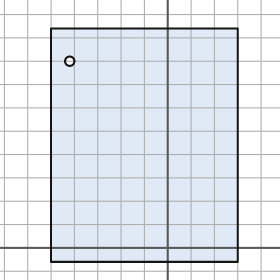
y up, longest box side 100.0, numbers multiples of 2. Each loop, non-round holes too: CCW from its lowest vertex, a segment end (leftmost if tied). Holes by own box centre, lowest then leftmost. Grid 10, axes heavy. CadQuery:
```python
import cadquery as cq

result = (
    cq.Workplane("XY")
    .moveTo(-50.0, -6.0)
    .lineTo(30.0, -6.0)
    .lineTo(30.0, 94.0)
    .lineTo(-50.0, 94.0)
    .close()
    .moveTo(-42.0, 80.0)
    .circle(2.0)
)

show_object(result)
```